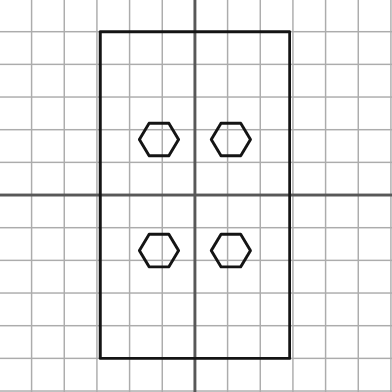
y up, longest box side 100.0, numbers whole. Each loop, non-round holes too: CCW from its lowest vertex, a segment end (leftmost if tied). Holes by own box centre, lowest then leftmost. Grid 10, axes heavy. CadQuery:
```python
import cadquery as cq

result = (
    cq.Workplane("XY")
    .moveTo(-29.0, -50.0)
    .lineTo(29.0, -50.0)
    .lineTo(29.0, 50.0)
    .lineTo(-29.0, 50.0)
    .close()
    .moveTo(-14.0, -22.0)
    .lineTo(-8.0, -22.0)
    .lineTo(-5.0, -17.0)
    .lineTo(-8.0, -12.0)
    .lineTo(-14.0, -12.0)
    .lineTo(-17.0, -17.0)
    .close()
    .moveTo(8.0, -22.0)
    .lineTo(14.0, -22.0)
    .lineTo(17.0, -17.0)
    .lineTo(14.0, -12.0)
    .lineTo(8.0, -12.0)
    .lineTo(5.0, -17.0)
    .close()
    .moveTo(-14.0, 12.0)
    .lineTo(-8.0, 12.0)
    .lineTo(-5.0, 17.0)
    .lineTo(-8.0, 22.0)
    .lineTo(-14.0, 22.0)
    .lineTo(-17.0, 17.0)
    .close()
    .moveTo(8.0, 12.0)
    .lineTo(14.0, 12.0)
    .lineTo(17.0, 17.0)
    .lineTo(14.0, 22.0)
    .lineTo(8.0, 22.0)
    .lineTo(5.0, 17.0)
    .close()
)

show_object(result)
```